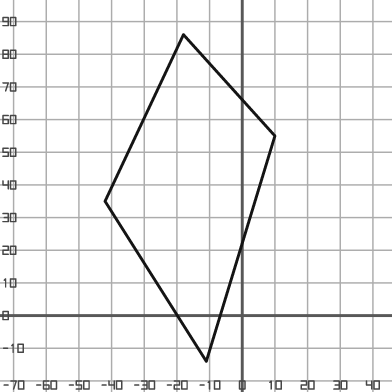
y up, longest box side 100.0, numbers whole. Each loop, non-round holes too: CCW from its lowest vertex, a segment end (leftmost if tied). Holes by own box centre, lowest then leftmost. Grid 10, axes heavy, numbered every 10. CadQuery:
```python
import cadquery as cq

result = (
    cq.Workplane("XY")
    .moveTo(-11.0, -14.0)
    .lineTo(10.0, 55.0)
    .lineTo(-18.0, 86.0)
    .lineTo(-42.0, 35.0)
    .close()
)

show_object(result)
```